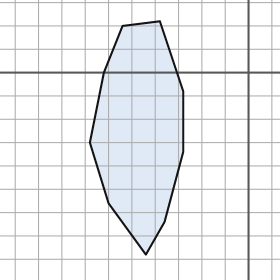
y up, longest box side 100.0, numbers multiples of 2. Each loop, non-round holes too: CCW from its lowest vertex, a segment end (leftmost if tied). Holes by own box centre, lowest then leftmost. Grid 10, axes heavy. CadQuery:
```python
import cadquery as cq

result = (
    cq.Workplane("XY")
    .moveTo(-44.0, -78.0)
    .lineTo(-36.0, -64.0)
    .lineTo(-28.0, -34.0)
    .lineTo(-28.0, -8.0)
    .lineTo(-38.0, 22.0)
    .lineTo(-54.0, 20.0)
    .lineTo(-62.0, 0.0)
    .lineTo(-68.0, -30.0)
    .lineTo(-60.0, -56.0)
    .close()
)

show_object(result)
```